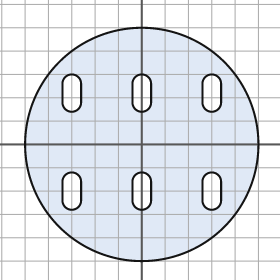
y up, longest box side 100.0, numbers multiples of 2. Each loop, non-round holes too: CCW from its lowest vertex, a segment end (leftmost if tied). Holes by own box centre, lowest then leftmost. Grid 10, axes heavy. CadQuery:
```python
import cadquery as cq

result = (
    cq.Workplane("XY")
    .moveTo(0.0, 0.0)
    .circle(50.0)
    .moveTo(-34.0, -24.0)
    .threePointArc((-30.0, -28.0), (-26.0, -24.0))
    .lineTo(-26.0, -16.0)
    .threePointArc((-30.0, -12.0), (-34.0, -16.0))
    .close()
    .moveTo(-4.0, -24.0)
    .threePointArc((0.0, -28.0), (4.0, -24.0))
    .lineTo(4.0, -16.0)
    .threePointArc((0.0, -12.0), (-4.0, -16.0))
    .close()
    .moveTo(26.0, -24.0)
    .threePointArc((30.0, -28.0), (34.0, -24.0))
    .lineTo(34.0, -16.0)
    .threePointArc((30.0, -12.0), (26.0, -16.0))
    .close()
    .moveTo(-34.0, 18.0)
    .threePointArc((-30.0, 14.0), (-26.0, 18.0))
    .lineTo(-26.0, 26.0)
    .threePointArc((-30.0, 30.0), (-34.0, 26.0))
    .close()
    .moveTo(-4.0, 18.0)
    .threePointArc((0.0, 14.0), (4.0, 18.0))
    .lineTo(4.0, 26.0)
    .threePointArc((0.0, 30.0), (-4.0, 26.0))
    .close()
    .moveTo(26.0, 18.0)
    .threePointArc((30.0, 14.0), (34.0, 18.0))
    .lineTo(34.0, 26.0)
    .threePointArc((30.0, 30.0), (26.0, 26.0))
    .close()
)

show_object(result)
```